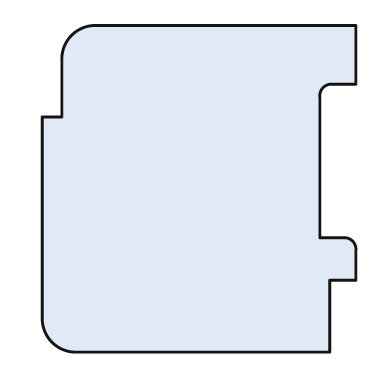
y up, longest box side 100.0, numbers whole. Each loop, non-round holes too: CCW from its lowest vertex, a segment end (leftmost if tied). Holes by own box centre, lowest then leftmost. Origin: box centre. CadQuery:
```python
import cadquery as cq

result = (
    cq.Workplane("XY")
    .moveTo(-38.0, -50.0)
    .lineTo(40.0, -50.0)
    .lineTo(40.0, -28.0)
    .lineTo(48.0, -28.0)
    .lineTo(48.0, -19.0)
    .threePointArc((47.0, -16.0), (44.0, -15.0))
    .lineTo(37.0, -15.0)
    .lineTo(37.0, 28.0)
    .threePointArc((38.0, 31.0), (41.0, 32.0))
    .lineTo(48.0, 32.0)
    .lineTo(48.0, 50.0)
    .lineTo(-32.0, 50.0)
    .threePointArc((-39.0, 47.0), (-42.0, 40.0))
    .lineTo(-42.0, 22.0)
    .lineTo(-48.0, 22.0)
    .lineTo(-48.0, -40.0)
    .threePointArc((-45.0, -47.0), (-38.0, -50.0))
    .close()
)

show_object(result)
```